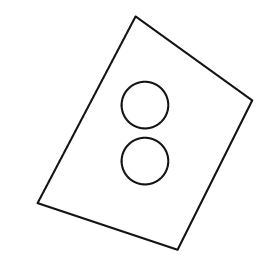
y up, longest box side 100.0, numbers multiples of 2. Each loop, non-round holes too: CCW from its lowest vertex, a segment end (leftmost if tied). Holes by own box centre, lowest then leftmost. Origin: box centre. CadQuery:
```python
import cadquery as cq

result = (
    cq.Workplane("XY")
    .moveTo(14.0, -50.0)
    .lineTo(46.0, 14.0)
    .lineTo(-4.0, 50.0)
    .lineTo(-46.0, -30.0)
    .close()
    .moveTo(0.0, -12.0)
    .circle(10.0)
    .moveTo(0.0, 12.0)
    .circle(10.0)
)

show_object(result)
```